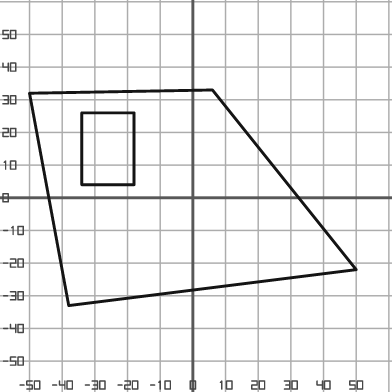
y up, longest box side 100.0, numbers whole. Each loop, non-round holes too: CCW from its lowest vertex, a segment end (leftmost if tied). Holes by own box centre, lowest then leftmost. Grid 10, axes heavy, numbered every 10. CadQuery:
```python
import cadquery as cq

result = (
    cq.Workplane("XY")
    .moveTo(-38.0, -33.0)
    .lineTo(50.0, -22.0)
    .lineTo(6.0, 33.0)
    .lineTo(-50.0, 32.0)
    .close()
    .moveTo(-34.0, 4.0)
    .lineTo(-18.0, 4.0)
    .lineTo(-18.0, 26.0)
    .lineTo(-34.0, 26.0)
    .close()
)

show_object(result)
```